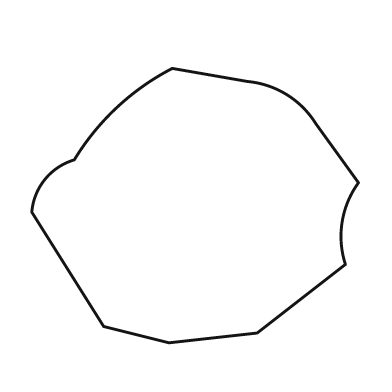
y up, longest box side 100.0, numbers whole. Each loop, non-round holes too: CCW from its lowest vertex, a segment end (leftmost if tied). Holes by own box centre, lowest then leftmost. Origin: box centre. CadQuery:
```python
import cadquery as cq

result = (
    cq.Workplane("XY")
    .moveTo(-8.0, -42.0)
    .lineTo(19.0, -39.0)
    .lineTo(46.0, -18.0)
    .threePointArc((45.0, -5.0), (50.0, 7.0))
    .lineTo(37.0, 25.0)
    .threePointArc((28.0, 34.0), (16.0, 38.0))
    .lineTo(-7.0, 42.0)
    .threePointArc((-24.0, 30.0), (-37.0, 14.0))
    .threePointArc((-46.0, 8.0), (-50.0, -2.0))
    .lineTo(-28.0, -37.0)
    .close()
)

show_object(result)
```